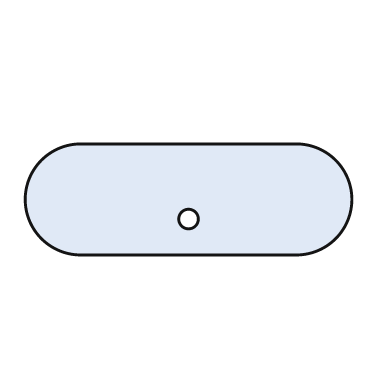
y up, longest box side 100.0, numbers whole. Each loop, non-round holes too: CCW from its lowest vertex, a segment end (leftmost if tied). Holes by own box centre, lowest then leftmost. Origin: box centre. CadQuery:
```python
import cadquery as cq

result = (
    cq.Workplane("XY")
    .moveTo(-33.0, -17.0)
    .lineTo(33.0, -17.0)
    .threePointArc((50.0, 0.0), (33.0, 17.0))
    .lineTo(-33.0, 17.0)
    .threePointArc((-50.0, 0.0), (-33.0, -17.0))
    .close()
    .moveTo(0.0, -6.0)
    .circle(3.0)
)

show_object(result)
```